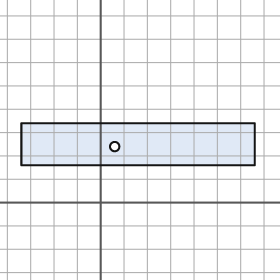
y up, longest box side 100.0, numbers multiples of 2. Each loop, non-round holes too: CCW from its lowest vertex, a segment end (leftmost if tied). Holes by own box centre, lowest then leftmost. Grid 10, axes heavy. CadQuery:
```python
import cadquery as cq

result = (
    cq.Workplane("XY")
    .moveTo(-34.0, 16.0)
    .lineTo(66.0, 16.0)
    .lineTo(66.0, 34.0)
    .lineTo(-34.0, 34.0)
    .close()
    .moveTo(6.0, 24.0)
    .circle(2.0)
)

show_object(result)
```